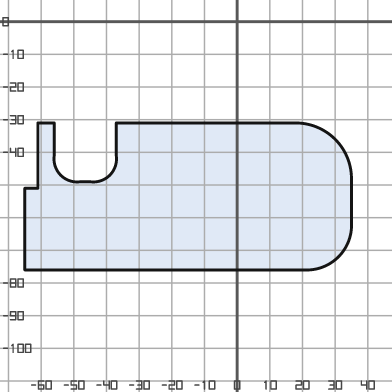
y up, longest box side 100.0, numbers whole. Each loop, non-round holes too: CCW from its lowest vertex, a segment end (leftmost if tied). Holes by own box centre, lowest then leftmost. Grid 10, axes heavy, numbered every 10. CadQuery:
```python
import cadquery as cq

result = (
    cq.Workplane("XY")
    .moveTo(-65.0, -76.0)
    .lineTo(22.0, -76.0)
    .threePointArc((31.0, -72.0), (35.0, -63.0))
    .lineTo(35.0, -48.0)
    .threePointArc((30.0, -36.0), (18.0, -31.0))
    .lineTo(-37.0, -31.0)
    .lineTo(-37.0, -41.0)
    .threePointArc((-39.0, -47.0), (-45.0, -49.0))
    .lineTo(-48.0, -49.0)
    .threePointArc((-54.0, -47.0), (-56.0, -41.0))
    .lineTo(-56.0, -31.0)
    .lineTo(-61.0, -31.0)
    .lineTo(-61.0, -51.0)
    .lineTo(-65.0, -51.0)
    .close()
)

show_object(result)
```